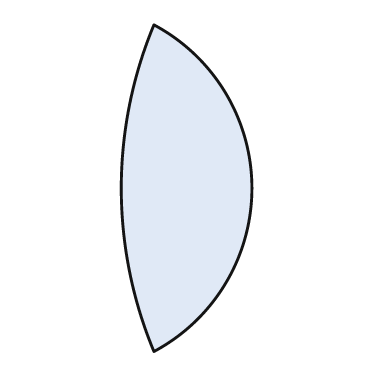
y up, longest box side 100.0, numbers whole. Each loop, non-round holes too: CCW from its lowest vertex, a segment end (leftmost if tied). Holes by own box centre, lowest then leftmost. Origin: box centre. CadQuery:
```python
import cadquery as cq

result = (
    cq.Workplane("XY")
    .moveTo(-10.0, -50.0)
    .threePointArc((20.0, 0.0), (-10.0, 50.0))
    .threePointArc((-20.0, 0.0), (-10.0, -50.0))
    .close()
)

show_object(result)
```